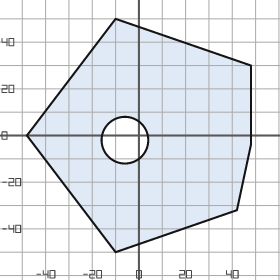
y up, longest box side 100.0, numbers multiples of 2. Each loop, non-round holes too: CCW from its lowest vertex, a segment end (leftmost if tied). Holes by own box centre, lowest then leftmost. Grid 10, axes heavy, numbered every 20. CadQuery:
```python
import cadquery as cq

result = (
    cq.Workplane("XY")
    .moveTo(-10.0, -50.0)
    .lineTo(42.0, -32.0)
    .lineTo(48.0, -4.0)
    .lineTo(48.0, 30.0)
    .lineTo(-10.0, 50.0)
    .lineTo(-48.0, 0.0)
    .close()
    .moveTo(-6.0, -2.0)
    .circle(10.0)
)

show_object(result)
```